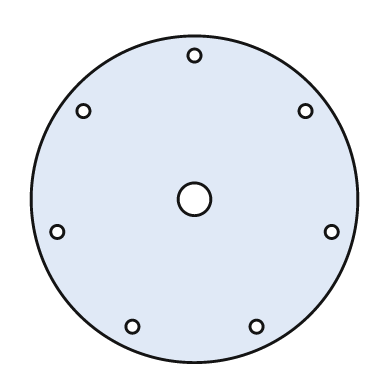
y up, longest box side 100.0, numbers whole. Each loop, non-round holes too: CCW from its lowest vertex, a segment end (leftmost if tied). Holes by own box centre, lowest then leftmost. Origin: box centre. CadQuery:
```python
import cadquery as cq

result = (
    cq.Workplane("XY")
    .moveTo(0.0, 0.0)
    .circle(50.0)
    .moveTo(-19.0, -39.0)
    .circle(2.0)
    .moveTo(19.0, -39.0)
    .circle(2.0)
    .moveTo(-42.0, -10.0)
    .circle(2.0)
    .moveTo(42.0, -10.0)
    .circle(2.0)
    .moveTo(0.0, 0.0)
    .circle(5.0)
    .moveTo(-34.0, 27.0)
    .circle(2.0)
    .moveTo(34.0, 27.0)
    .circle(2.0)
    .moveTo(0.0, 44.0)
    .circle(2.0)
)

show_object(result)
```